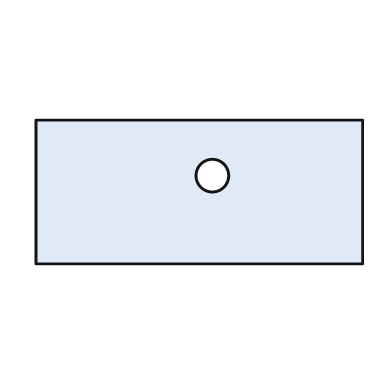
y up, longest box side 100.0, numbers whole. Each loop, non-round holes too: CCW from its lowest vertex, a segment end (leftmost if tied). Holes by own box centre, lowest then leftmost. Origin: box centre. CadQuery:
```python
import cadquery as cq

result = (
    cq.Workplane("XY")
    .moveTo(-50.0, -22.0)
    .lineTo(50.0, -22.0)
    .lineTo(50.0, 22.0)
    .lineTo(-50.0, 22.0)
    .close()
    .moveTo(4.0, 5.0)
    .circle(5.0)
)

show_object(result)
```